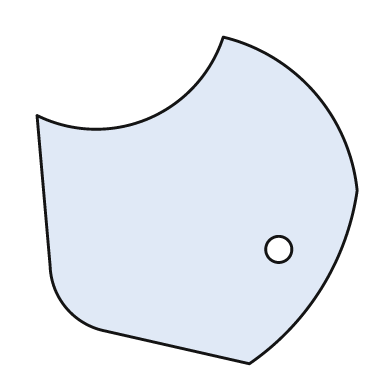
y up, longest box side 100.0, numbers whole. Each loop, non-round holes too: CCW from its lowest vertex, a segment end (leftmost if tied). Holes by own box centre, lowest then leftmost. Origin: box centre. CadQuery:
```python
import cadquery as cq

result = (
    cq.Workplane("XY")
    .moveTo(16.0, -50.0)
    .threePointArc((38.0, -27.0), (49.0, 3.0))
    .threePointArc((36.0, 33.0), (8.0, 50.0))
    .threePointArc((-15.0, 25.0), (-49.0, 26.0))
    .lineTo(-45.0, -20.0)
    .threePointArc((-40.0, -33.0), (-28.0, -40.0))
    .close()
    .moveTo(25.0, -15.0)
    .circle(4.0)
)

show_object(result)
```